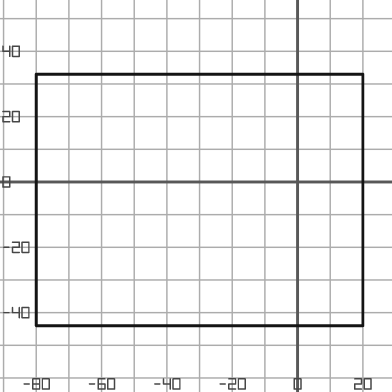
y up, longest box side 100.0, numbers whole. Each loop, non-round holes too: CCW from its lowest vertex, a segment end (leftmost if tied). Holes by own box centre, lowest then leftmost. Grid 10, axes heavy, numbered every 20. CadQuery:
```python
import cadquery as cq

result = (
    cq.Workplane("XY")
    .moveTo(-80.0, -44.0)
    .lineTo(20.0, -44.0)
    .lineTo(20.0, 33.0)
    .lineTo(-80.0, 33.0)
    .close()
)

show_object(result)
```